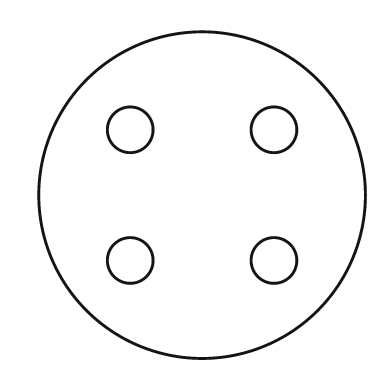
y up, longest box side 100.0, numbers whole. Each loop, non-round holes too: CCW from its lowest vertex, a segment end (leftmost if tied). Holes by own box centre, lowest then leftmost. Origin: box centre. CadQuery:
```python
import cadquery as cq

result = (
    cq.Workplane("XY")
    .moveTo(0.0, 0.0)
    .circle(50.0)
    .moveTo(-22.0, -20.0)
    .circle(7.0)
    .moveTo(22.0, -20.0)
    .circle(7.0)
    .moveTo(-22.0, 20.0)
    .circle(7.0)
    .moveTo(22.0, 20.0)
    .circle(7.0)
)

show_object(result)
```